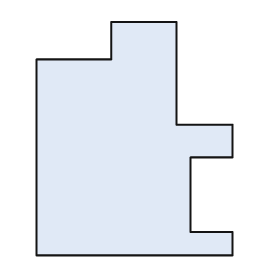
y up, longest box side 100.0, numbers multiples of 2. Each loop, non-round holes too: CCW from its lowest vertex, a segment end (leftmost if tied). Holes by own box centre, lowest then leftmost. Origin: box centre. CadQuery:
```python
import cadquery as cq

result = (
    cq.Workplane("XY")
    .moveTo(-42.0, -50.0)
    .lineTo(42.0, -50.0)
    .lineTo(42.0, -40.0)
    .lineTo(24.0, -40.0)
    .lineTo(24.0, -8.0)
    .lineTo(42.0, -8.0)
    .lineTo(42.0, 6.0)
    .lineTo(18.0, 6.0)
    .lineTo(18.0, 50.0)
    .lineTo(-10.0, 50.0)
    .lineTo(-10.0, 34.0)
    .lineTo(-42.0, 34.0)
    .close()
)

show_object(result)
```